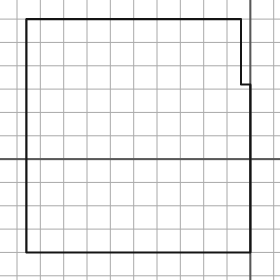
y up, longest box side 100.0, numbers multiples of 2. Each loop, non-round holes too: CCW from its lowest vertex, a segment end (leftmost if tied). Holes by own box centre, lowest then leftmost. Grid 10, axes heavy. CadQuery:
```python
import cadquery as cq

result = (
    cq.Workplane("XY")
    .moveTo(-96.0, -40.0)
    .lineTo(0.0, -40.0)
    .lineTo(0.0, 32.0)
    .lineTo(-4.0, 32.0)
    .lineTo(-4.0, 60.0)
    .lineTo(-96.0, 60.0)
    .close()
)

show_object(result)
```